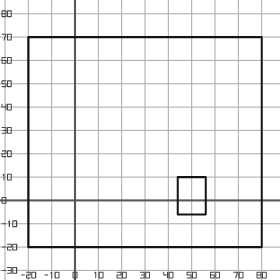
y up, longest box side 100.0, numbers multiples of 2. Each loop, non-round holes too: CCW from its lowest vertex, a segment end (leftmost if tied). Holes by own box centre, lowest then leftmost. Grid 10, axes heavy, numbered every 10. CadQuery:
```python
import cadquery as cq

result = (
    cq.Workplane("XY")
    .moveTo(-20.0, -20.0)
    .lineTo(80.0, -20.0)
    .lineTo(80.0, 70.0)
    .lineTo(-20.0, 70.0)
    .close()
    .moveTo(44.0, -6.0)
    .lineTo(56.0, -6.0)
    .lineTo(56.0, 10.0)
    .lineTo(44.0, 10.0)
    .close()
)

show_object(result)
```